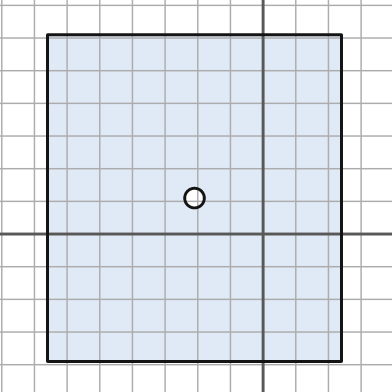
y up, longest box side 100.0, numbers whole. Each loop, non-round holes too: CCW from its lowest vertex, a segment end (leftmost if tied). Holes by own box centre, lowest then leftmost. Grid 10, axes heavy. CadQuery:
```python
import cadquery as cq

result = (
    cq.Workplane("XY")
    .moveTo(-66.0, -39.0)
    .lineTo(24.0, -39.0)
    .lineTo(24.0, 61.0)
    .lineTo(-66.0, 61.0)
    .close()
    .moveTo(-21.0, 11.0)
    .circle(3.0)
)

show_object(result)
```